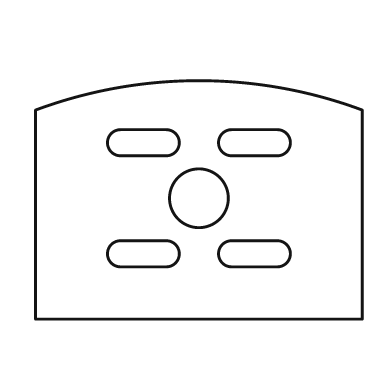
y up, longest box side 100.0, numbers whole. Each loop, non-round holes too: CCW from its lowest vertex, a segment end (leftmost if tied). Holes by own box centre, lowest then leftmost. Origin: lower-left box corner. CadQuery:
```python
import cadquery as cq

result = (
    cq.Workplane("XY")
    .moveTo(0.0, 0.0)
    .lineTo(100.0, 0.0)
    .lineTo(100.0, 64.0)
    .threePointArc((50.0, 73.0), (0.0, 64.0))
    .close()
    .moveTo(26.0, 16.0)
    .lineTo(40.0, 16.0)
    .threePointArc((44.0, 20.0), (40.0, 24.0))
    .lineTo(26.0, 24.0)
    .threePointArc((22.0, 20.0), (26.0, 16.0))
    .close()
    .moveTo(60.0, 16.0)
    .lineTo(74.0, 16.0)
    .threePointArc((78.0, 20.0), (74.0, 24.0))
    .lineTo(60.0, 24.0)
    .threePointArc((56.0, 20.0), (60.0, 16.0))
    .close()
    .moveTo(50.0, 37.0)
    .circle(9.0)
    .moveTo(26.0, 50.0)
    .lineTo(40.0, 50.0)
    .threePointArc((44.0, 54.0), (40.0, 58.0))
    .lineTo(26.0, 58.0)
    .threePointArc((22.0, 54.0), (26.0, 50.0))
    .close()
    .moveTo(60.0, 50.0)
    .lineTo(74.0, 50.0)
    .threePointArc((78.0, 54.0), (74.0, 58.0))
    .lineTo(60.0, 58.0)
    .threePointArc((56.0, 54.0), (60.0, 50.0))
    .close()
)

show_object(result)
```